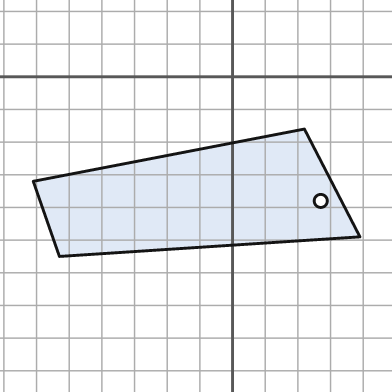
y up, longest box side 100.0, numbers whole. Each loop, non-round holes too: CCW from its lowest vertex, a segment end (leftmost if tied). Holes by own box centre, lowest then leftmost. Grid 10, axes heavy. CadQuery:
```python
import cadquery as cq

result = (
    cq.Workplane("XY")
    .moveTo(-53.0, -55.0)
    .lineTo(39.0, -49.0)
    .lineTo(22.0, -16.0)
    .lineTo(-61.0, -32.0)
    .close()
    .moveTo(27.0, -38.0)
    .circle(2.0)
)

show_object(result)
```